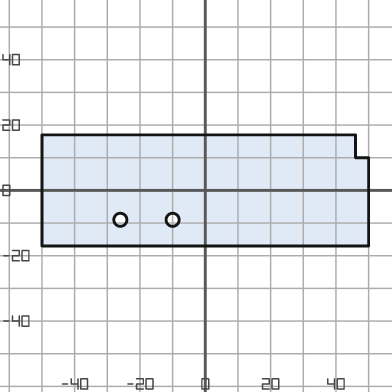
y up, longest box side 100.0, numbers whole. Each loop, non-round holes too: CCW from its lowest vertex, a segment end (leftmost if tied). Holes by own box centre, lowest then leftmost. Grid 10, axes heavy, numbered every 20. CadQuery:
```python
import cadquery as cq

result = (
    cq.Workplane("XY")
    .moveTo(-50.0, -17.0)
    .lineTo(50.0, -17.0)
    .lineTo(50.0, 10.0)
    .lineTo(46.0, 10.0)
    .lineTo(46.0, 17.0)
    .lineTo(-50.0, 17.0)
    .close()
    .moveTo(-26.0, -9.0)
    .circle(2.0)
    .moveTo(-10.0, -9.0)
    .circle(2.0)
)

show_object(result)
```